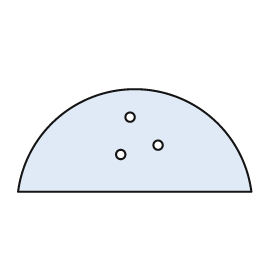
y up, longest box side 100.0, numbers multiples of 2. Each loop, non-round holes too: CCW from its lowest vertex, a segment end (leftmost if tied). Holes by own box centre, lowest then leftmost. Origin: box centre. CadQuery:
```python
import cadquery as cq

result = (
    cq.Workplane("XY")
    .moveTo(-50.0, -22.0)
    .lineTo(50.0, -22.0)
    .threePointArc((0.0, 22.0), (-50.0, -22.0))
    .close()
    .moveTo(-6.0, -6.0)
    .circle(2.0)
    .moveTo(10.0, -2.0)
    .circle(2.0)
    .moveTo(-2.0, 10.0)
    .circle(2.0)
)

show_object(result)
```